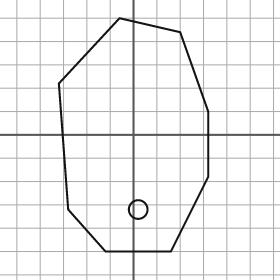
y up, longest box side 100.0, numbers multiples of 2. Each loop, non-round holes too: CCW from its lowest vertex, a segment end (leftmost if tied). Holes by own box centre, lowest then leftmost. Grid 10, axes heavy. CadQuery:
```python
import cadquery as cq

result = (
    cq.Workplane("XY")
    .moveTo(-12.0, -50.0)
    .lineTo(16.0, -50.0)
    .lineTo(32.0, -18.0)
    .lineTo(32.0, 10.0)
    .lineTo(20.0, 44.0)
    .lineTo(-6.0, 50.0)
    .lineTo(-32.0, 22.0)
    .lineTo(-28.0, -32.0)
    .close()
    .moveTo(2.0, -32.0)
    .circle(4.0)
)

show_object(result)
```